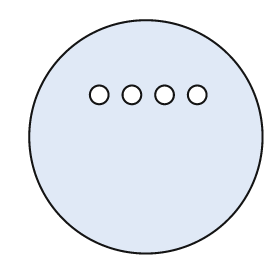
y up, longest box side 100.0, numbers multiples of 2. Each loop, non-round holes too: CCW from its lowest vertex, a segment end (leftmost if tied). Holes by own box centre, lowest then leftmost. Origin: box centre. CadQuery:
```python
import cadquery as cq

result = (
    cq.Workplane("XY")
    .moveTo(0.0, 0.0)
    .circle(50.0)
    .moveTo(-20.0, 18.0)
    .circle(4.0)
    .moveTo(-6.0, 18.0)
    .circle(4.0)
    .moveTo(8.0, 18.0)
    .circle(4.0)
    .moveTo(22.0, 18.0)
    .circle(4.0)
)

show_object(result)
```